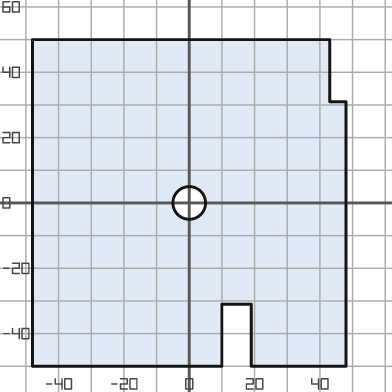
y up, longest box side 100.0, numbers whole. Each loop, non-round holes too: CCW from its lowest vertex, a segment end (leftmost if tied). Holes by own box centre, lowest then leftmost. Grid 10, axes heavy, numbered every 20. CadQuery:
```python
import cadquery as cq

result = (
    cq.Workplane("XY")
    .moveTo(-48.0, -50.0)
    .lineTo(10.0, -50.0)
    .lineTo(10.0, -31.0)
    .lineTo(19.0, -31.0)
    .lineTo(19.0, -50.0)
    .lineTo(48.0, -50.0)
    .lineTo(48.0, 31.0)
    .lineTo(43.0, 31.0)
    .lineTo(43.0, 50.0)
    .lineTo(-48.0, 50.0)
    .close()
    .moveTo(0.0, 0.0)
    .circle(5.0)
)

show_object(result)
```